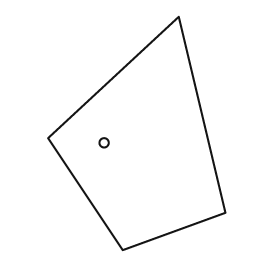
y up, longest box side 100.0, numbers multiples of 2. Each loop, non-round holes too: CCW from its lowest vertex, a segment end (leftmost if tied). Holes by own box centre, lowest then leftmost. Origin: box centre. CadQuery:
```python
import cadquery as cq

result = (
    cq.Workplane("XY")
    .moveTo(-6.0, -50.0)
    .lineTo(38.0, -34.0)
    .lineTo(18.0, 50.0)
    .lineTo(-38.0, -2.0)
    .close()
    .moveTo(-14.0, -4.0)
    .circle(2.0)
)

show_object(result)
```